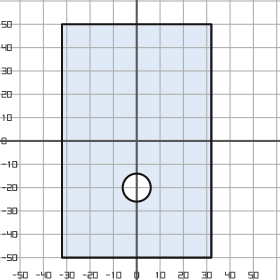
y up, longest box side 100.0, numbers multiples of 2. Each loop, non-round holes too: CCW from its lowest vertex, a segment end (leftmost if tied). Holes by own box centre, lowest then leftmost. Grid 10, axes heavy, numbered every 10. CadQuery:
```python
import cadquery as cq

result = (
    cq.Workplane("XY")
    .moveTo(-32.0, -50.0)
    .lineTo(32.0, -50.0)
    .lineTo(32.0, 50.0)
    .lineTo(-32.0, 50.0)
    .close()
    .moveTo(0.0, -20.0)
    .circle(6.0)
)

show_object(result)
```